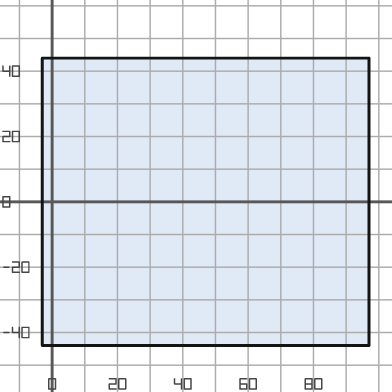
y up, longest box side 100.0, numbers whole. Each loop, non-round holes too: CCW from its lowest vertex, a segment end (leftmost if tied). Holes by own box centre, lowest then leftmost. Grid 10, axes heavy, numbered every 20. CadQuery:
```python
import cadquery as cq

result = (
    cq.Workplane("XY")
    .moveTo(-3.0, -44.0)
    .lineTo(97.0, -44.0)
    .lineTo(97.0, 44.0)
    .lineTo(-3.0, 44.0)
    .close()
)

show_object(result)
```